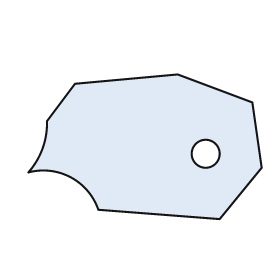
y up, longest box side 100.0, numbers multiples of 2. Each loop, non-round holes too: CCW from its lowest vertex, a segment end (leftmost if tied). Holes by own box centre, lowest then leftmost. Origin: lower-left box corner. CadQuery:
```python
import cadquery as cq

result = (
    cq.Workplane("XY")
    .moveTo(82.0, 0.0)
    .lineTo(100.0, 22.0)
    .lineTo(96.0, 50.0)
    .lineTo(64.0, 62.0)
    .lineTo(20.0, 58.0)
    .lineTo(8.0, 42.0)
    .threePointArc((6.0, 30.0), (0.0, 20.0))
    .threePointArc((18.0, 18.0), (30.0, 4.0))
    .close()
    .moveTo(76.0, 28.0)
    .circle(6.0)
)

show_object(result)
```